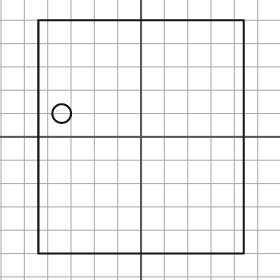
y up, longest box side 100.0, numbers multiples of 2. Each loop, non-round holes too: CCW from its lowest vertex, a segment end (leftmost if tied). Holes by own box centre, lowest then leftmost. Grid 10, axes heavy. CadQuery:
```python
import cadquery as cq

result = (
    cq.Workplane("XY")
    .moveTo(-44.0, -50.0)
    .lineTo(44.0, -50.0)
    .lineTo(44.0, 50.0)
    .lineTo(-44.0, 50.0)
    .close()
    .moveTo(-34.0, 10.0)
    .circle(4.0)
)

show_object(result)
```